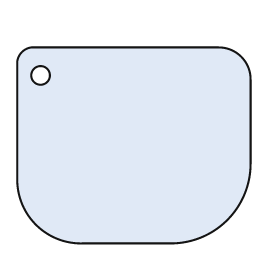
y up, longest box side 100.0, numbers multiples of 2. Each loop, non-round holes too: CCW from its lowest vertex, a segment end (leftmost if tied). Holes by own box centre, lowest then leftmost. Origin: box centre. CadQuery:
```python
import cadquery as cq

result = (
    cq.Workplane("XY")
    .moveTo(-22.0, -42.0)
    .lineTo(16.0, -42.0)
    .threePointArc((40.0, -32.0), (50.0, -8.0))
    .lineTo(50.0, 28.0)
    .threePointArc((46.0, 38.0), (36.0, 42.0))
    .lineTo(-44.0, 42.0)
    .threePointArc((-48.0, 40.0), (-50.0, 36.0))
    .lineTo(-50.0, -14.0)
    .threePointArc((-42.0, -34.0), (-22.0, -42.0))
    .close()
    .moveTo(-40.0, 30.0)
    .circle(4.0)
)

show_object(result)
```